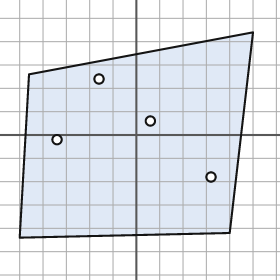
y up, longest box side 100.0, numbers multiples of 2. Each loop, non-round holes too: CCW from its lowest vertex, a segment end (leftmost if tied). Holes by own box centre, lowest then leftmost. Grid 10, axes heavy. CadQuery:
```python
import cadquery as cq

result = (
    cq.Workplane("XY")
    .moveTo(-50.0, -44.0)
    .lineTo(40.0, -42.0)
    .lineTo(50.0, 44.0)
    .lineTo(-46.0, 26.0)
    .close()
    .moveTo(32.0, -18.0)
    .circle(2.0)
    .moveTo(-34.0, -2.0)
    .circle(2.0)
    .moveTo(6.0, 6.0)
    .circle(2.0)
    .moveTo(-16.0, 24.0)
    .circle(2.0)
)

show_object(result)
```